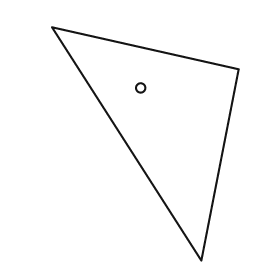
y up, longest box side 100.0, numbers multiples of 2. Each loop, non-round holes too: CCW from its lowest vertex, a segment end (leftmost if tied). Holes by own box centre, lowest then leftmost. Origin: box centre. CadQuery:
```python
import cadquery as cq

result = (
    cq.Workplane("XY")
    .moveTo(24.0, -50.0)
    .lineTo(40.0, 32.0)
    .lineTo(-40.0, 50.0)
    .close()
    .moveTo(-2.0, 24.0)
    .circle(2.0)
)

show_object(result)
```